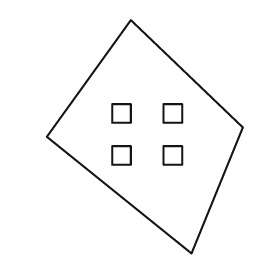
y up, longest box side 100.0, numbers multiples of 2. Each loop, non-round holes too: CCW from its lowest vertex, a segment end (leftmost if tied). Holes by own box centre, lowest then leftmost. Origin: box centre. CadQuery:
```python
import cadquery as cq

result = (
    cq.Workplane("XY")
    .moveTo(20.0, -50.0)
    .lineTo(42.0, 4.0)
    .lineTo(-6.0, 50.0)
    .lineTo(-42.0, 0.0)
    .close()
    .moveTo(-14.0, -12.0)
    .lineTo(-6.0, -12.0)
    .lineTo(-6.0, -4.0)
    .lineTo(-14.0, -4.0)
    .close()
    .moveTo(8.0, -12.0)
    .lineTo(16.0, -12.0)
    .lineTo(16.0, -4.0)
    .lineTo(8.0, -4.0)
    .close()
    .moveTo(-14.0, 6.0)
    .lineTo(-6.0, 6.0)
    .lineTo(-6.0, 14.0)
    .lineTo(-14.0, 14.0)
    .close()
    .moveTo(8.0, 6.0)
    .lineTo(16.0, 6.0)
    .lineTo(16.0, 14.0)
    .lineTo(8.0, 14.0)
    .close()
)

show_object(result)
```